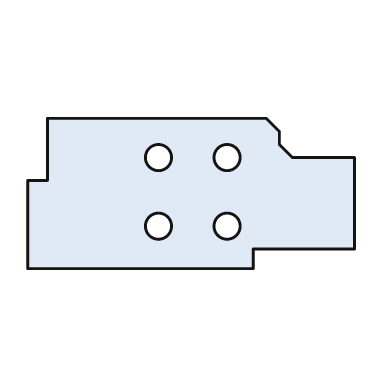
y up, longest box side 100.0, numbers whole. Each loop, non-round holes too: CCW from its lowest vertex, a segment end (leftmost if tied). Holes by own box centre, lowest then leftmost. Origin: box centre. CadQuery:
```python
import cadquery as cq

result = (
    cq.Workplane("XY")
    .moveTo(-50.0, -23.0)
    .lineTo(19.0, -23.0)
    .lineTo(19.0, -17.0)
    .lineTo(50.0, -17.0)
    .lineTo(50.0, 11.0)
    .lineTo(31.0, 11.0)
    .lineTo(27.0, 15.0)
    .lineTo(27.0, 19.0)
    .lineTo(23.0, 23.0)
    .lineTo(-44.0, 23.0)
    .lineTo(-44.0, 4.0)
    .lineTo(-50.0, 4.0)
    .close()
    .moveTo(-10.0, -10.0)
    .circle(4.0)
    .moveTo(11.0, -10.0)
    .circle(4.0)
    .moveTo(-10.0, 11.0)
    .circle(4.0)
    .moveTo(11.0, 11.0)
    .circle(4.0)
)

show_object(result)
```